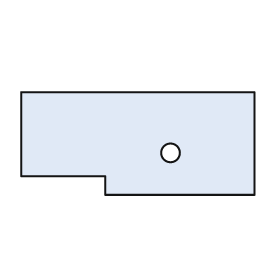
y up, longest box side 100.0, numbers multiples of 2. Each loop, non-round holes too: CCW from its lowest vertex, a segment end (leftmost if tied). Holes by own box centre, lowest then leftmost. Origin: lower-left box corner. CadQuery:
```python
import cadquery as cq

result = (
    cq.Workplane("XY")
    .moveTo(36.0, 0.0)
    .lineTo(100.0, 0.0)
    .lineTo(100.0, 44.0)
    .lineTo(0.0, 44.0)
    .lineTo(0.0, 8.0)
    .lineTo(36.0, 8.0)
    .close()
    .moveTo(64.0, 18.0)
    .circle(4.0)
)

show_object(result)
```